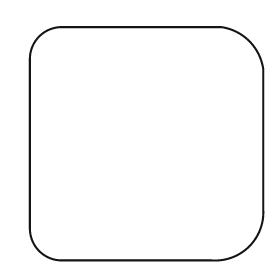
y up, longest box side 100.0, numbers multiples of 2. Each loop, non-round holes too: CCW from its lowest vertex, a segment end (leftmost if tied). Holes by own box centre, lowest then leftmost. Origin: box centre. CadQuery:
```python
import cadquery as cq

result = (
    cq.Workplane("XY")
    .moveTo(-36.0, -50.0)
    .lineTo(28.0, -50.0)
    .threePointArc((44.0, -44.0), (50.0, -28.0))
    .lineTo(50.0, 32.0)
    .threePointArc((44.0, 44.0), (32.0, 50.0))
    .lineTo(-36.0, 50.0)
    .threePointArc((-46.0, 46.0), (-50.0, 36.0))
    .lineTo(-50.0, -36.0)
    .threePointArc((-46.0, -46.0), (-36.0, -50.0))
    .close()
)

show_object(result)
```